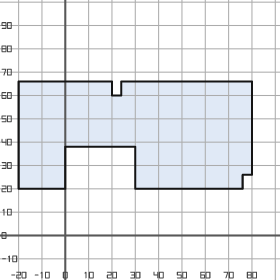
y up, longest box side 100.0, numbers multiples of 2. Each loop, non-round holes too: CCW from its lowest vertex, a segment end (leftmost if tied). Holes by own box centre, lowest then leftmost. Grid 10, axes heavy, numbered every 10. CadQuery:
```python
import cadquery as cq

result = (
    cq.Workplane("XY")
    .moveTo(-20.0, 20.0)
    .lineTo(0.0, 20.0)
    .lineTo(0.0, 38.0)
    .lineTo(30.0, 38.0)
    .lineTo(30.0, 20.0)
    .lineTo(76.0, 20.0)
    .lineTo(76.0, 26.0)
    .lineTo(80.0, 26.0)
    .lineTo(80.0, 66.0)
    .lineTo(24.0, 66.0)
    .lineTo(24.0, 60.0)
    .lineTo(20.0, 60.0)
    .lineTo(20.0, 66.0)
    .lineTo(-20.0, 66.0)
    .close()
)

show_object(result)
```